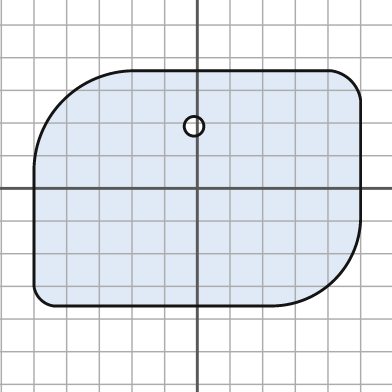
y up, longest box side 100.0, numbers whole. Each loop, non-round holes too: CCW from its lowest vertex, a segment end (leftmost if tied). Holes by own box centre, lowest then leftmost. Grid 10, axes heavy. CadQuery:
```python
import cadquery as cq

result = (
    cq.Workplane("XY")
    .moveTo(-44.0, -36.0)
    .lineTo(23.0, -36.0)
    .threePointArc((42.0, -28.0), (50.0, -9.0))
    .lineTo(50.0, 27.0)
    .threePointArc((47.0, 33.0), (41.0, 36.0))
    .lineTo(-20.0, 36.0)
    .threePointArc((-41.0, 27.0), (-50.0, 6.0))
    .lineTo(-50.0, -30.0)
    .threePointArc((-48.0, -34.0), (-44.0, -36.0))
    .close()
    .moveTo(-1.0, 19.0)
    .circle(3.0)
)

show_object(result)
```